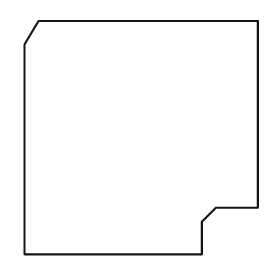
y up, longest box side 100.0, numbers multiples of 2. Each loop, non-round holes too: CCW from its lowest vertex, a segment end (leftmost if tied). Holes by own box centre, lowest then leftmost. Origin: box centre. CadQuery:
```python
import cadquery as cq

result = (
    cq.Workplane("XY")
    .moveTo(-50.0, -50.0)
    .lineTo(26.0, -50.0)
    .lineTo(26.0, -36.0)
    .lineTo(32.0, -30.0)
    .lineTo(50.0, -30.0)
    .lineTo(50.0, 50.0)
    .lineTo(-44.0, 50.0)
    .lineTo(-50.0, 40.0)
    .close()
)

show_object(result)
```